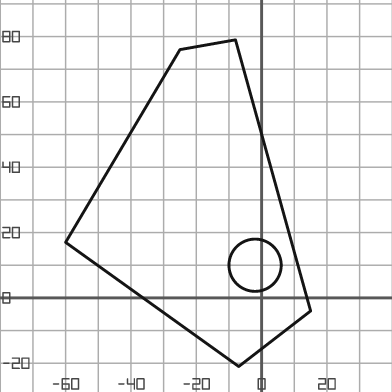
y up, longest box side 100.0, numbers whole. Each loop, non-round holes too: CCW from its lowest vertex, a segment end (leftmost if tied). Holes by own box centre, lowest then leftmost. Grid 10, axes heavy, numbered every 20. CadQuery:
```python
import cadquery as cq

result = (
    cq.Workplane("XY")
    .moveTo(-7.0, -21.0)
    .lineTo(15.0, -4.0)
    .lineTo(-8.0, 79.0)
    .lineTo(-25.0, 76.0)
    .lineTo(-60.0, 17.0)
    .close()
    .moveTo(-2.0, 10.0)
    .circle(8.0)
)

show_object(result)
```